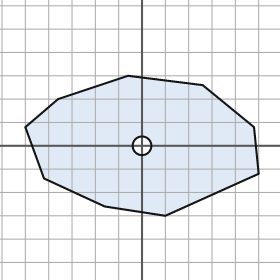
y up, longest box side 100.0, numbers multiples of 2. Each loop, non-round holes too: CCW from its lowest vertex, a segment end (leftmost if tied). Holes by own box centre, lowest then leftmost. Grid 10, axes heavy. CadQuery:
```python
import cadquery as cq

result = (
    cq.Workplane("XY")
    .moveTo(10.0, -30.0)
    .lineTo(50.0, -12.0)
    .lineTo(48.0, 8.0)
    .lineTo(26.0, 26.0)
    .lineTo(-6.0, 30.0)
    .lineTo(-36.0, 20.0)
    .lineTo(-50.0, 8.0)
    .lineTo(-42.0, -14.0)
    .lineTo(-16.0, -26.0)
    .close()
    .moveTo(0.0, 0.0)
    .circle(4.0)
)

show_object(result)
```